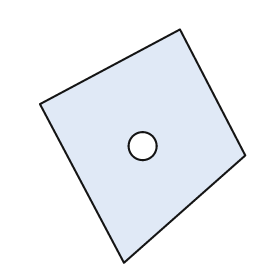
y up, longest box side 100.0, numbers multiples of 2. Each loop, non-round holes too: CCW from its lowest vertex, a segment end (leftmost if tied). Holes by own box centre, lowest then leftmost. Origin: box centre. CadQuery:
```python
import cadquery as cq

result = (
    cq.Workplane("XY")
    .moveTo(-8.0, -50.0)
    .lineTo(44.0, -4.0)
    .lineTo(16.0, 50.0)
    .lineTo(-44.0, 18.0)
    .close()
    .moveTo(0.0, 0.0)
    .circle(6.0)
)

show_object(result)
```